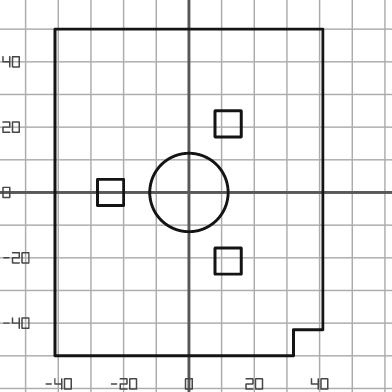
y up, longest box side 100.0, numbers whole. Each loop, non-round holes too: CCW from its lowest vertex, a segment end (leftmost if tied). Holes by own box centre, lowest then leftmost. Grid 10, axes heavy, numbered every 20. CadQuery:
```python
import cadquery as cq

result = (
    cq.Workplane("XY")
    .moveTo(-41.0, -50.0)
    .lineTo(32.0, -50.0)
    .lineTo(32.0, -42.0)
    .lineTo(41.0, -42.0)
    .lineTo(41.0, 50.0)
    .lineTo(-41.0, 50.0)
    .close()
    .moveTo(8.0, -25.0)
    .lineTo(16.0, -25.0)
    .lineTo(16.0, -17.0)
    .lineTo(8.0, -17.0)
    .close()
    .moveTo(-28.0, -4.0)
    .lineTo(-20.0, -4.0)
    .lineTo(-20.0, 4.0)
    .lineTo(-28.0, 4.0)
    .close()
    .moveTo(0.0, 0.0)
    .circle(12.0)
    .moveTo(8.0, 17.0)
    .lineTo(16.0, 17.0)
    .lineTo(16.0, 25.0)
    .lineTo(8.0, 25.0)
    .close()
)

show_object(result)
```